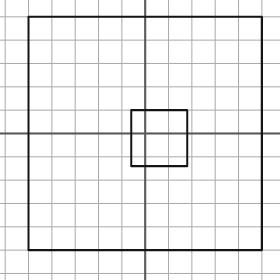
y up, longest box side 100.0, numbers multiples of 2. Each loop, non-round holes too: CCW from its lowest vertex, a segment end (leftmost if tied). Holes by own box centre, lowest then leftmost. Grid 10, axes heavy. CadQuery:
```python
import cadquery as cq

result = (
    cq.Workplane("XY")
    .moveTo(-50.0, -50.0)
    .lineTo(50.0, -50.0)
    .lineTo(50.0, 50.0)
    .lineTo(-50.0, 50.0)
    .close()
    .moveTo(-6.0, -14.0)
    .lineTo(18.0, -14.0)
    .lineTo(18.0, 10.0)
    .lineTo(-6.0, 10.0)
    .close()
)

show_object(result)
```